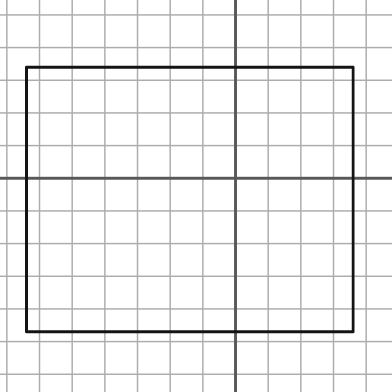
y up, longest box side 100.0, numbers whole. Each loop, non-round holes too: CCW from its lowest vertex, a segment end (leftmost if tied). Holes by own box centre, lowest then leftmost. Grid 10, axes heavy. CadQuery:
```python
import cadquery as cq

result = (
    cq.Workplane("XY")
    .moveTo(-64.0, -47.0)
    .lineTo(36.0, -47.0)
    .lineTo(36.0, 34.0)
    .lineTo(-64.0, 34.0)
    .close()
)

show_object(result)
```